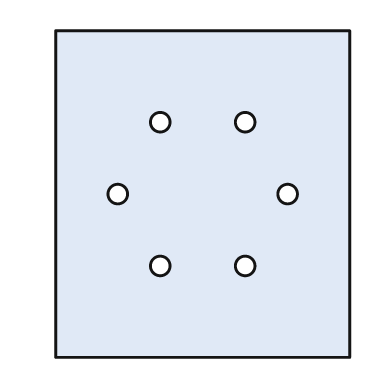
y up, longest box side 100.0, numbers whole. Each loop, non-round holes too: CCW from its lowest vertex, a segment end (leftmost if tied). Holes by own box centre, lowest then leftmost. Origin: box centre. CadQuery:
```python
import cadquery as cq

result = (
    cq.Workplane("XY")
    .moveTo(-45.0, -50.0)
    .lineTo(45.0, -50.0)
    .lineTo(45.0, 50.0)
    .lineTo(-45.0, 50.0)
    .close()
    .moveTo(-13.0, -22.0)
    .circle(3.0)
    .moveTo(13.0, -22.0)
    .circle(3.0)
    .moveTo(-26.0, 0.0)
    .circle(3.0)
    .moveTo(26.0, 0.0)
    .circle(3.0)
    .moveTo(-13.0, 22.0)
    .circle(3.0)
    .moveTo(13.0, 22.0)
    .circle(3.0)
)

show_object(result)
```